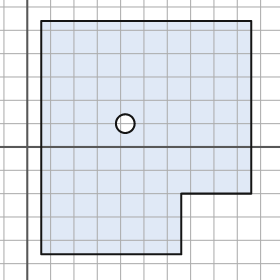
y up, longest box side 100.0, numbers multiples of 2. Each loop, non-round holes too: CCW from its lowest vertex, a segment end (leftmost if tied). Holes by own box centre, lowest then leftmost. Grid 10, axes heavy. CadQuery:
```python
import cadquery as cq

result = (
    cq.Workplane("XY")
    .moveTo(6.0, -46.0)
    .lineTo(66.0, -46.0)
    .lineTo(66.0, -20.0)
    .lineTo(96.0, -20.0)
    .lineTo(96.0, 54.0)
    .lineTo(6.0, 54.0)
    .close()
    .moveTo(42.0, 10.0)
    .circle(4.0)
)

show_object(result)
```